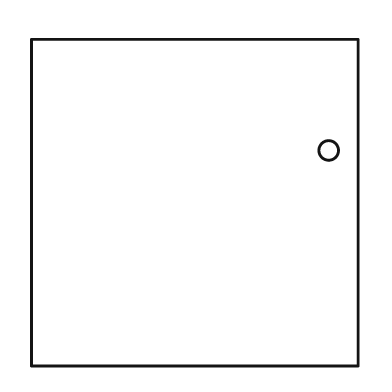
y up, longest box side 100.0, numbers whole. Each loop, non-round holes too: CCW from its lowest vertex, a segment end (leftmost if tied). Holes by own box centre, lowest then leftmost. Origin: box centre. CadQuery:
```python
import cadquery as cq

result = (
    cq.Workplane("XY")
    .moveTo(-50.0, -50.0)
    .lineTo(50.0, -50.0)
    .lineTo(50.0, 50.0)
    .lineTo(-50.0, 50.0)
    .close()
    .moveTo(41.0, 16.0)
    .circle(3.0)
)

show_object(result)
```